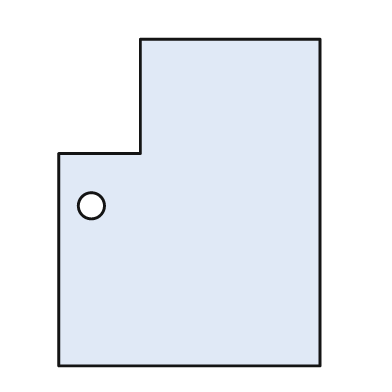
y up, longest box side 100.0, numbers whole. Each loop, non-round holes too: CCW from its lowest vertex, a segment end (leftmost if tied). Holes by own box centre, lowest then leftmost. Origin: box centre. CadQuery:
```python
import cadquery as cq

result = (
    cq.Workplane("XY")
    .moveTo(-40.0, -50.0)
    .lineTo(40.0, -50.0)
    .lineTo(40.0, 50.0)
    .lineTo(-15.0, 50.0)
    .lineTo(-15.0, 15.0)
    .lineTo(-40.0, 15.0)
    .close()
    .moveTo(-30.0, -1.0)
    .circle(4.0)
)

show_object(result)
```